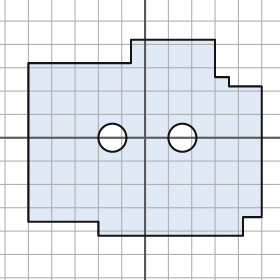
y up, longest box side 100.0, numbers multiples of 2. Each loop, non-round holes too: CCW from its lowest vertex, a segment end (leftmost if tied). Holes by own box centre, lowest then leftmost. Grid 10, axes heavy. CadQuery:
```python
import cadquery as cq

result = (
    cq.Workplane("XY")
    .moveTo(-20.0, -42.0)
    .lineTo(42.0, -42.0)
    .lineTo(42.0, -34.0)
    .lineTo(50.0, -34.0)
    .lineTo(50.0, 22.0)
    .lineTo(36.0, 22.0)
    .lineTo(36.0, 26.0)
    .lineTo(30.0, 26.0)
    .lineTo(30.0, 42.0)
    .lineTo(-6.0, 42.0)
    .lineTo(-6.0, 32.0)
    .lineTo(-50.0, 32.0)
    .lineTo(-50.0, -36.0)
    .lineTo(-20.0, -36.0)
    .close()
    .moveTo(-14.0, 0.0)
    .circle(6.0)
    .moveTo(16.0, 0.0)
    .circle(6.0)
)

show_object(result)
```